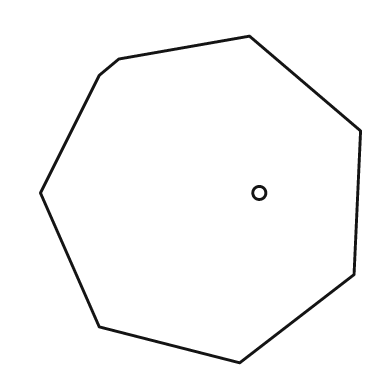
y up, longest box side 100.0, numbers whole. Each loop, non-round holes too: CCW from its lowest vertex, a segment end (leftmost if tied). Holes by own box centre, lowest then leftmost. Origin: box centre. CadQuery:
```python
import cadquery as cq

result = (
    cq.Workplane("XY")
    .moveTo(12.0, -50.0)
    .lineTo(47.0, -23.0)
    .lineTo(49.0, 21.0)
    .lineTo(15.0, 50.0)
    .lineTo(-25.0, 43.0)
    .lineTo(-31.0, 38.0)
    .lineTo(-49.0, 2.0)
    .lineTo(-31.0, -39.0)
    .close()
    .moveTo(18.0, 2.0)
    .circle(2.0)
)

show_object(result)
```